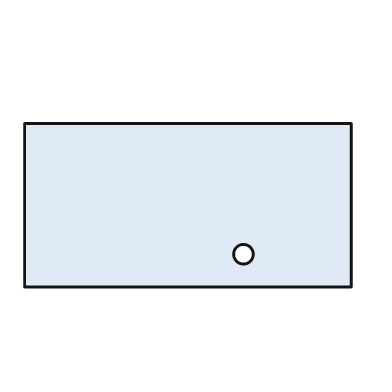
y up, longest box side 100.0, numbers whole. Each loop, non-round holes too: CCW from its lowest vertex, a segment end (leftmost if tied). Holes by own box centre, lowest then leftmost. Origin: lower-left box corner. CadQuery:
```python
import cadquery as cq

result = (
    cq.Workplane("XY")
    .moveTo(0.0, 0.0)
    .lineTo(100.0, 0.0)
    .lineTo(100.0, 50.0)
    .lineTo(0.0, 50.0)
    .close()
    .moveTo(67.0, 10.0)
    .circle(3.0)
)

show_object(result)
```